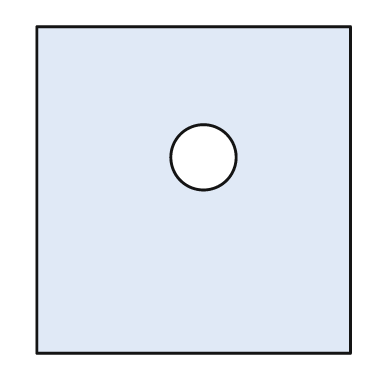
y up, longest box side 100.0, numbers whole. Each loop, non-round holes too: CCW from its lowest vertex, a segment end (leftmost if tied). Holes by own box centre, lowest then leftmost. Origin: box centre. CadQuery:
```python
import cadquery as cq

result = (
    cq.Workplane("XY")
    .moveTo(-48.0, -50.0)
    .lineTo(48.0, -50.0)
    .lineTo(48.0, 50.0)
    .lineTo(-48.0, 50.0)
    .close()
    .moveTo(3.0, 10.0)
    .circle(10.0)
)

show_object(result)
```